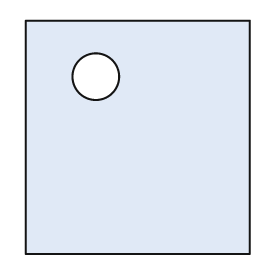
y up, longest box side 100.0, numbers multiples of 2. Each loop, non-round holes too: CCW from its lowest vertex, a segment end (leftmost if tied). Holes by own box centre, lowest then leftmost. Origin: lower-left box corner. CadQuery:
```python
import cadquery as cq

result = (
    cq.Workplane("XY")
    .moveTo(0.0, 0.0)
    .lineTo(96.0, 0.0)
    .lineTo(96.0, 100.0)
    .lineTo(0.0, 100.0)
    .close()
    .moveTo(30.0, 76.0)
    .circle(10.0)
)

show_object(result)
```